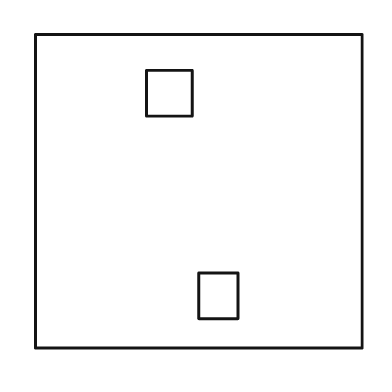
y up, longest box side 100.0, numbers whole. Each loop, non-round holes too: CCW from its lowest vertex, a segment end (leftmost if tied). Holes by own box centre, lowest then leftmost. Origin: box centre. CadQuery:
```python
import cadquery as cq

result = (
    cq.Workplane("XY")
    .moveTo(-50.0, -48.0)
    .lineTo(50.0, -48.0)
    .lineTo(50.0, 48.0)
    .lineTo(-50.0, 48.0)
    .close()
    .moveTo(0.0, -39.0)
    .lineTo(12.0, -39.0)
    .lineTo(12.0, -25.0)
    .lineTo(0.0, -25.0)
    .close()
    .moveTo(-16.0, 23.0)
    .lineTo(-2.0, 23.0)
    .lineTo(-2.0, 37.0)
    .lineTo(-16.0, 37.0)
    .close()
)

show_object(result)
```